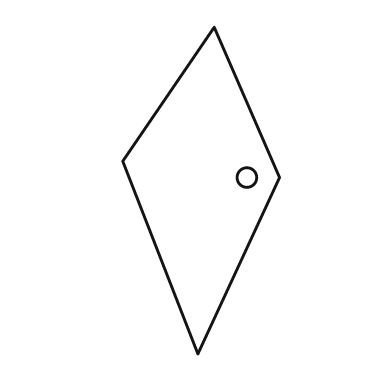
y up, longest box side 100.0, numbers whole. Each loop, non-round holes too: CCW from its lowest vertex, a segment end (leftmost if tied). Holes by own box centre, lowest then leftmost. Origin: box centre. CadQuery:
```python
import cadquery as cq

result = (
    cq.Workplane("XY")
    .moveTo(-1.0, -50.0)
    .lineTo(24.0, 4.0)
    .lineTo(4.0, 50.0)
    .lineTo(-24.0, 9.0)
    .close()
    .moveTo(14.0, 4.0)
    .circle(3.0)
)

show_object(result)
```